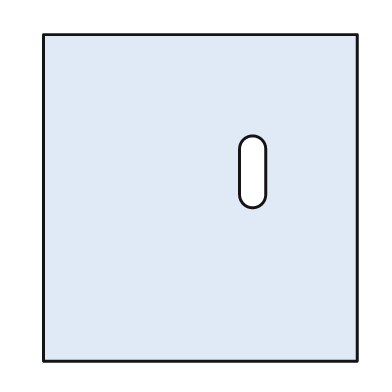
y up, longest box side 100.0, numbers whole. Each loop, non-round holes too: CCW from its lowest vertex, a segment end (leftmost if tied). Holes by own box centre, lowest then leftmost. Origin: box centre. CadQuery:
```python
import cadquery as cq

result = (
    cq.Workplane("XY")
    .moveTo(-48.0, -50.0)
    .lineTo(48.0, -50.0)
    .lineTo(48.0, 50.0)
    .lineTo(-48.0, 50.0)
    .close()
    .moveTo(12.0, 1.0)
    .threePointArc((16.0, -3.0), (20.0, 1.0))
    .lineTo(20.0, 15.0)
    .threePointArc((16.0, 19.0), (12.0, 15.0))
    .close()
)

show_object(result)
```